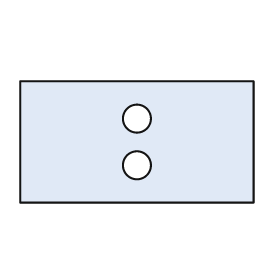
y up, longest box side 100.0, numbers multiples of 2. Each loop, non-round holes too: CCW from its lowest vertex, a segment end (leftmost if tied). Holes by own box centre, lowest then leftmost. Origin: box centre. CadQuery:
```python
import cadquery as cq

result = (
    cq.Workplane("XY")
    .moveTo(-50.0, -26.0)
    .lineTo(50.0, -26.0)
    .lineTo(50.0, 26.0)
    .lineTo(-50.0, 26.0)
    .close()
    .moveTo(0.0, -10.0)
    .circle(6.0)
    .moveTo(0.0, 10.0)
    .circle(6.0)
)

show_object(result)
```